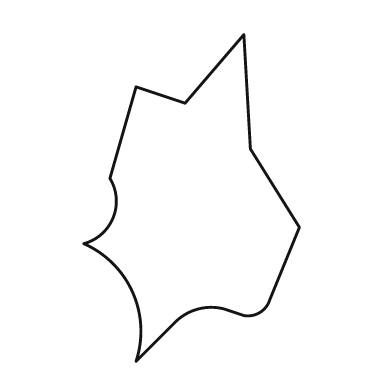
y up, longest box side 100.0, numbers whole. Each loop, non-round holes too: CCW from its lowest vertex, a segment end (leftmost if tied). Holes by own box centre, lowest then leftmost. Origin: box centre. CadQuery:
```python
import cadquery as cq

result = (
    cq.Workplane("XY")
    .moveTo(-17.0, -50.0)
    .lineTo(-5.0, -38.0)
    .threePointArc((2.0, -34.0), (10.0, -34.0))
    .lineTo(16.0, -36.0)
    .threePointArc((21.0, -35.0), (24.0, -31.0))
    .lineTo(33.0, -9.0)
    .lineTo(18.0, 15.0)
    .lineTo(16.0, 50.0)
    .lineTo(-2.0, 29.0)
    .lineTo(-17.0, 34.0)
    .lineTo(-25.0, 6.0)
    .threePointArc((-24.0, -6.0), (-33.0, -14.0))
    .threePointArc((-18.0, -29.0), (-17.0, -50.0))
    .close()
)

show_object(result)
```